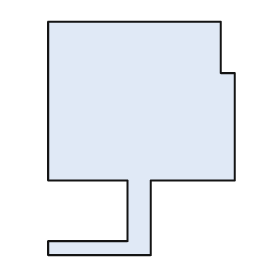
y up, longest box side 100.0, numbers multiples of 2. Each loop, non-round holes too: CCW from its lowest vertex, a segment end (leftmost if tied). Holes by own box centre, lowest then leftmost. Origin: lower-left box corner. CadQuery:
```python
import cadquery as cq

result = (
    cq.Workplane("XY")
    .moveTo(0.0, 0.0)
    .lineTo(44.0, 0.0)
    .lineTo(44.0, 32.0)
    .lineTo(80.0, 32.0)
    .lineTo(80.0, 78.0)
    .lineTo(74.0, 78.0)
    .lineTo(74.0, 100.0)
    .lineTo(0.0, 100.0)
    .lineTo(0.0, 32.0)
    .lineTo(34.0, 32.0)
    .lineTo(34.0, 6.0)
    .lineTo(0.0, 6.0)
    .close()
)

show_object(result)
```